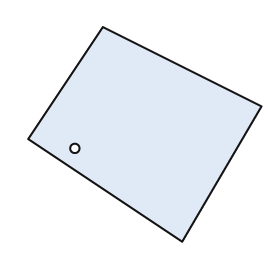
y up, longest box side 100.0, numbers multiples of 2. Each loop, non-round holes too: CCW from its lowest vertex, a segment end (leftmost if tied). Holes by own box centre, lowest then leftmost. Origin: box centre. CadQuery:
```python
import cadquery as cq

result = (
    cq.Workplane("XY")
    .moveTo(16.0, -46.0)
    .lineTo(50.0, 12.0)
    .lineTo(-18.0, 46.0)
    .lineTo(-50.0, -2.0)
    .close()
    .moveTo(-30.0, -6.0)
    .circle(2.0)
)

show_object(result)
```